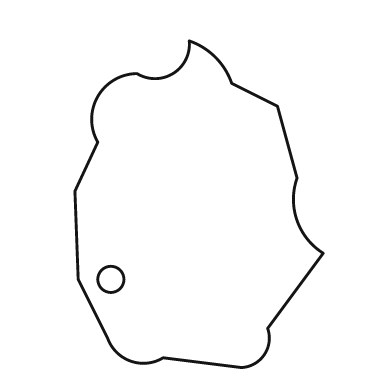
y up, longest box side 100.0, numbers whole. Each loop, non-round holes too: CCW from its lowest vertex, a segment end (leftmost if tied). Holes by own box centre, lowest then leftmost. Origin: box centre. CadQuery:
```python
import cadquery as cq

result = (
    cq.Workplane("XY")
    .moveTo(13.0, -50.0)
    .threePointArc((20.0, -46.0), (21.0, -38.0))
    .lineTo(38.0, -15.0)
    .threePointArc((30.0, -5.0), (30.0, 8.0))
    .lineTo(24.0, 30.0)
    .lineTo(10.0, 37.0)
    .threePointArc((5.0, 45.0), (-3.0, 50.0))
    .threePointArc((-8.0, 40.0), (-19.0, 40.0))
    .threePointArc((-31.0, 33.0), (-31.0, 19.0))
    .lineTo(-38.0, 4.0)
    .lineTo(-37.0, -23.0)
    .lineTo(-28.0, -41.0)
    .threePointArc((-21.0, -48.0), (-11.0, -47.0))
    .close()
    .moveTo(-27.0, -23.0)
    .circle(4.0)
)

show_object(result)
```